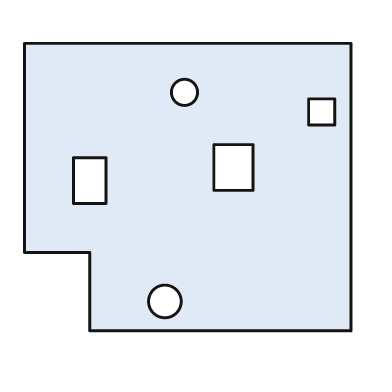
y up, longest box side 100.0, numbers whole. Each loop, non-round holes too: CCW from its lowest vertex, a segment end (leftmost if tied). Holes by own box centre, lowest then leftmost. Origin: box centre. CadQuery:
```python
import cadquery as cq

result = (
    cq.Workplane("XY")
    .moveTo(-30.0, -44.0)
    .lineTo(50.0, -44.0)
    .lineTo(50.0, 44.0)
    .lineTo(-50.0, 44.0)
    .lineTo(-50.0, -20.0)
    .lineTo(-30.0, -20.0)
    .close()
    .moveTo(-7.0, -35.0)
    .circle(5.0)
    .moveTo(-35.0, -5.0)
    .lineTo(-25.0, -5.0)
    .lineTo(-25.0, 9.0)
    .lineTo(-35.0, 9.0)
    .close()
    .moveTo(8.0, -1.0)
    .lineTo(20.0, -1.0)
    .lineTo(20.0, 13.0)
    .lineTo(8.0, 13.0)
    .close()
    .moveTo(37.0, 19.0)
    .lineTo(45.0, 19.0)
    .lineTo(45.0, 27.0)
    .lineTo(37.0, 27.0)
    .close()
    .moveTo(-1.0, 29.0)
    .circle(4.0)
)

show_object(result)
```